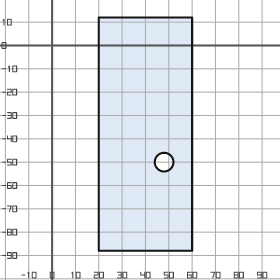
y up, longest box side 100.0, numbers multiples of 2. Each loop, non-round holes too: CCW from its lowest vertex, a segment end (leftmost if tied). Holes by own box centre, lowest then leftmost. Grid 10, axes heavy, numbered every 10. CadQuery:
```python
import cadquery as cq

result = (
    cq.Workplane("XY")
    .moveTo(20.0, -88.0)
    .lineTo(60.0, -88.0)
    .lineTo(60.0, 12.0)
    .lineTo(20.0, 12.0)
    .close()
    .moveTo(48.0, -50.0)
    .circle(4.0)
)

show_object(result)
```